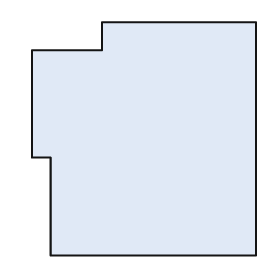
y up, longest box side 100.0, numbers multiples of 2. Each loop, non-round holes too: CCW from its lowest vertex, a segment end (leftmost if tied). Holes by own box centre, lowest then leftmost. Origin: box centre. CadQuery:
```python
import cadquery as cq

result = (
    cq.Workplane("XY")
    .moveTo(-40.0, -50.0)
    .lineTo(48.0, -50.0)
    .lineTo(48.0, 50.0)
    .lineTo(-18.0, 50.0)
    .lineTo(-18.0, 38.0)
    .lineTo(-48.0, 38.0)
    .lineTo(-48.0, -8.0)
    .lineTo(-40.0, -8.0)
    .close()
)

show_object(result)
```